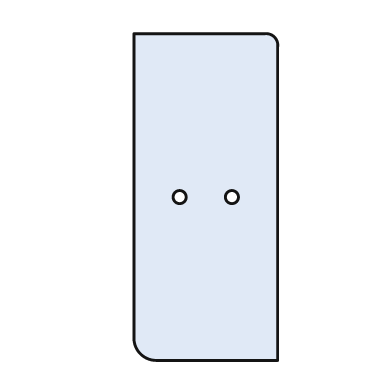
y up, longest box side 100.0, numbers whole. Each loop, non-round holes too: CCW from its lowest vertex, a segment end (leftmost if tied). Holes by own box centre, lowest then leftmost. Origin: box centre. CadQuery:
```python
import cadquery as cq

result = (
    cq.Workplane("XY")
    .moveTo(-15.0, -50.0)
    .lineTo(22.0, -50.0)
    .lineTo(22.0, 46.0)
    .threePointArc((21.0, 49.0), (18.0, 50.0))
    .lineTo(-22.0, 50.0)
    .lineTo(-22.0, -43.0)
    .threePointArc((-20.0, -48.0), (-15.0, -50.0))
    .close()
    .moveTo(-8.0, 0.0)
    .circle(2.0)
    .moveTo(8.0, 0.0)
    .circle(2.0)
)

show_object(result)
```